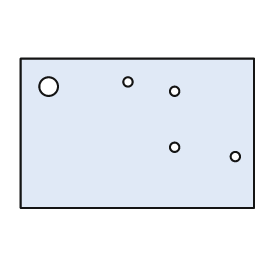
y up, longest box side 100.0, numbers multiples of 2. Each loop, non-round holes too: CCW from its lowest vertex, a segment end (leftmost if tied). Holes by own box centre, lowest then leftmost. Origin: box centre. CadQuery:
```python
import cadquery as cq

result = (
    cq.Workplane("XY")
    .moveTo(-50.0, -32.0)
    .lineTo(50.0, -32.0)
    .lineTo(50.0, 32.0)
    .lineTo(-50.0, 32.0)
    .close()
    .moveTo(42.0, -10.0)
    .circle(2.0)
    .moveTo(16.0, -6.0)
    .circle(2.0)
    .moveTo(16.0, 18.0)
    .circle(2.0)
    .moveTo(-38.0, 20.0)
    .circle(4.0)
    .moveTo(-4.0, 22.0)
    .circle(2.0)
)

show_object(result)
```